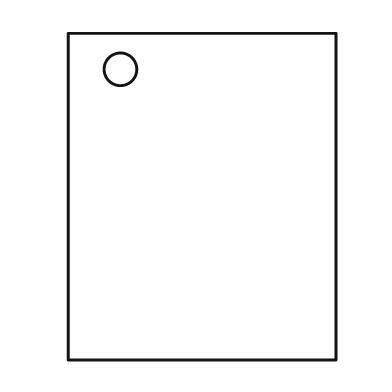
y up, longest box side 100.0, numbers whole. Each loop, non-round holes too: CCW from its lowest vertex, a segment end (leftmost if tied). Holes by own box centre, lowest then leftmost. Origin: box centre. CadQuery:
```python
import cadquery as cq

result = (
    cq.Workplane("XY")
    .moveTo(-41.0, -50.0)
    .lineTo(41.0, -50.0)
    .lineTo(41.0, 50.0)
    .lineTo(-41.0, 50.0)
    .close()
    .moveTo(-25.0, 39.0)
    .circle(5.0)
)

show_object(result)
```